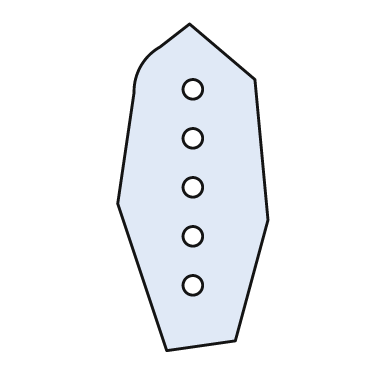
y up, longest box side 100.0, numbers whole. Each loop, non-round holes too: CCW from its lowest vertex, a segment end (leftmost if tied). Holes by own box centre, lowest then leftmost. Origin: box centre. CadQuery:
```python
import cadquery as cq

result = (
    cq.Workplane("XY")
    .moveTo(-8.0, -50.0)
    .lineTo(13.0, -47.0)
    .lineTo(23.0, -10.0)
    .lineTo(19.0, 33.0)
    .lineTo(-1.0, 50.0)
    .lineTo(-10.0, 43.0)
    .threePointArc((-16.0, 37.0), (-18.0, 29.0))
    .lineTo(-23.0, -5.0)
    .close()
    .moveTo(0.0, -30.0)
    .circle(3.0)
    .moveTo(0.0, -15.0)
    .circle(3.0)
    .moveTo(0.0, 0.0)
    .circle(3.0)
    .moveTo(0.0, 15.0)
    .circle(3.0)
    .moveTo(0.0, 30.0)
    .circle(3.0)
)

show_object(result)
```